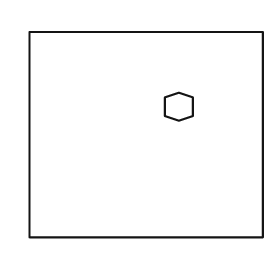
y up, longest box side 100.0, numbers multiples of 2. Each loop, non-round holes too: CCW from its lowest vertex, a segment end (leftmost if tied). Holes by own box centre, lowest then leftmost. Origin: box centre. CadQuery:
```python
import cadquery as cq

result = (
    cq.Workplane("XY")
    .moveTo(-50.0, -44.0)
    .lineTo(50.0, -44.0)
    .lineTo(50.0, 44.0)
    .lineTo(-50.0, 44.0)
    .close()
    .moveTo(14.0, 6.0)
    .lineTo(20.0, 8.0)
    .lineTo(20.0, 16.0)
    .lineTo(14.0, 18.0)
    .lineTo(8.0, 16.0)
    .lineTo(8.0, 8.0)
    .close()
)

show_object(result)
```